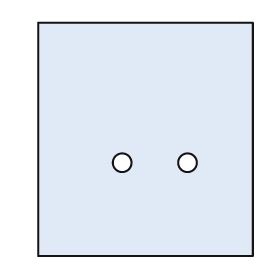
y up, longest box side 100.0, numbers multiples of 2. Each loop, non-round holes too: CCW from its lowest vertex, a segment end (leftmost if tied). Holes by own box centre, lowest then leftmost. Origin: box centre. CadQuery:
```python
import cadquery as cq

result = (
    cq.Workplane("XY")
    .moveTo(-46.0, -50.0)
    .lineTo(46.0, -50.0)
    .lineTo(46.0, 50.0)
    .lineTo(-46.0, 50.0)
    .close()
    .moveTo(-10.0, -10.0)
    .circle(4.0)
    .moveTo(18.0, -10.0)
    .circle(4.0)
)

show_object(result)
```